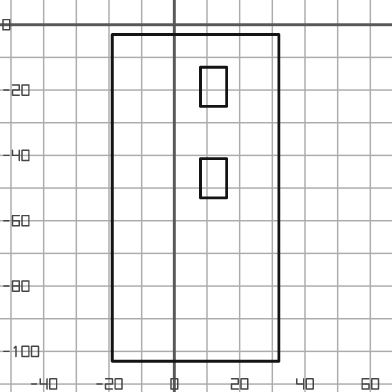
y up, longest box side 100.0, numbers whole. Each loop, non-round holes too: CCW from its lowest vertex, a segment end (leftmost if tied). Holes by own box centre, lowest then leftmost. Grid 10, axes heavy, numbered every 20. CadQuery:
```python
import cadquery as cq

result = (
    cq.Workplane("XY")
    .moveTo(-19.0, -103.0)
    .lineTo(32.0, -103.0)
    .lineTo(32.0, -3.0)
    .lineTo(-19.0, -3.0)
    .close()
    .moveTo(8.0, -53.0)
    .lineTo(16.0, -53.0)
    .lineTo(16.0, -41.0)
    .lineTo(8.0, -41.0)
    .close()
    .moveTo(8.0, -25.0)
    .lineTo(16.0, -25.0)
    .lineTo(16.0, -13.0)
    .lineTo(8.0, -13.0)
    .close()
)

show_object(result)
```